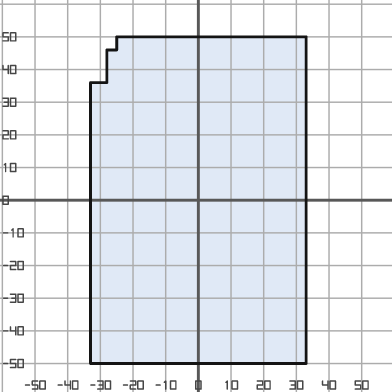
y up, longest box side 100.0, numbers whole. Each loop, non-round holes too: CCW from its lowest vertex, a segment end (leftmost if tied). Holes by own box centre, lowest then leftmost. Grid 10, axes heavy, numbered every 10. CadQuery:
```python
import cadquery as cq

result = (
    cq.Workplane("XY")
    .moveTo(-33.0, -50.0)
    .lineTo(33.0, -50.0)
    .lineTo(33.0, 50.0)
    .lineTo(-25.0, 50.0)
    .lineTo(-25.0, 46.0)
    .lineTo(-28.0, 46.0)
    .lineTo(-28.0, 36.0)
    .lineTo(-33.0, 36.0)
    .close()
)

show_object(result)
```